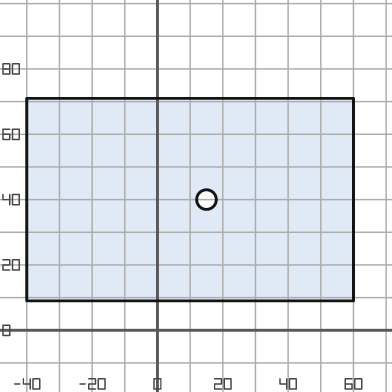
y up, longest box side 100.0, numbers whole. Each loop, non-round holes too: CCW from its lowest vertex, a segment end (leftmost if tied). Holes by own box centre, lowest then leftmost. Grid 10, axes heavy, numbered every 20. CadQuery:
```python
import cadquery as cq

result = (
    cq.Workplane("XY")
    .moveTo(-40.0, 9.0)
    .lineTo(60.0, 9.0)
    .lineTo(60.0, 71.0)
    .lineTo(-40.0, 71.0)
    .close()
    .moveTo(15.0, 40.0)
    .circle(3.0)
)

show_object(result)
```